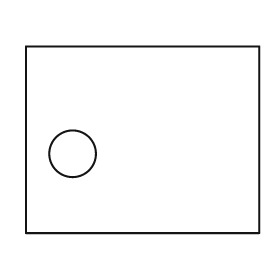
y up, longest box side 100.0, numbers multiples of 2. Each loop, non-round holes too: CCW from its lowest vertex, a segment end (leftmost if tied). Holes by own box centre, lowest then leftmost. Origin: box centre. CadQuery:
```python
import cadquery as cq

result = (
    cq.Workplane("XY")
    .moveTo(-50.0, -40.0)
    .lineTo(50.0, -40.0)
    .lineTo(50.0, 40.0)
    .lineTo(-50.0, 40.0)
    .close()
    .moveTo(-30.0, -6.0)
    .circle(10.0)
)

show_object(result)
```